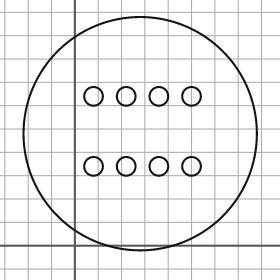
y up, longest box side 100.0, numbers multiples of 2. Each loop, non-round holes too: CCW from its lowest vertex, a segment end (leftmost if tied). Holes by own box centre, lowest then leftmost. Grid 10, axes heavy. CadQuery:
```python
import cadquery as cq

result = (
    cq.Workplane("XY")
    .moveTo(28.0, 48.0)
    .circle(50.0)
    .moveTo(8.0, 34.0)
    .circle(4.0)
    .moveTo(22.0, 34.0)
    .circle(4.0)
    .moveTo(36.0, 34.0)
    .circle(4.0)
    .moveTo(50.0, 34.0)
    .circle(4.0)
    .moveTo(8.0, 64.0)
    .circle(4.0)
    .moveTo(22.0, 64.0)
    .circle(4.0)
    .moveTo(36.0, 64.0)
    .circle(4.0)
    .moveTo(50.0, 64.0)
    .circle(4.0)
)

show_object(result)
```